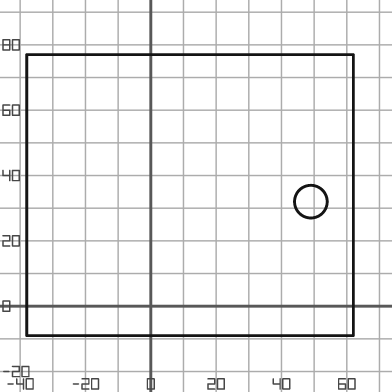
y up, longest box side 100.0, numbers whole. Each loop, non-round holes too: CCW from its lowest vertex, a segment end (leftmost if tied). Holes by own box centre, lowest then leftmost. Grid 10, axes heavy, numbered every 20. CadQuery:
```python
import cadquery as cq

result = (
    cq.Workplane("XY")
    .moveTo(-38.0, -9.0)
    .lineTo(62.0, -9.0)
    .lineTo(62.0, 77.0)
    .lineTo(-38.0, 77.0)
    .close()
    .moveTo(49.0, 32.0)
    .circle(5.0)
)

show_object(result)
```